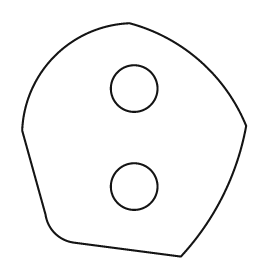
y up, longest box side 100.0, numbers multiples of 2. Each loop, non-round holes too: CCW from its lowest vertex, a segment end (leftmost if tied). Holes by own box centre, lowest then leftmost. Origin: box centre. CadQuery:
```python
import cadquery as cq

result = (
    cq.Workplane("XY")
    .moveTo(20.0, -50.0)
    .threePointArc((38.0, -24.0), (48.0, 6.0))
    .threePointArc((28.0, 34.0), (-2.0, 50.0))
    .threePointArc((-34.0, 36.0), (-48.0, 4.0))
    .lineTo(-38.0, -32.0)
    .threePointArc((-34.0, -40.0), (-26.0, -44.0))
    .close()
    .moveTo(0.0, -20.0)
    .circle(10.0)
    .moveTo(0.0, 22.0)
    .circle(10.0)
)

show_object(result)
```